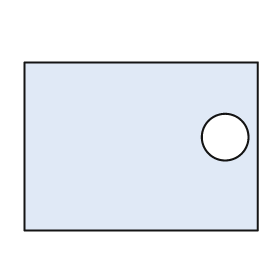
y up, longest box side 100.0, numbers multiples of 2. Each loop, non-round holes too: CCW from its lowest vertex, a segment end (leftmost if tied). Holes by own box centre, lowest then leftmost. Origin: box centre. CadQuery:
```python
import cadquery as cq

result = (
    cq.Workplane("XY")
    .moveTo(-50.0, -36.0)
    .lineTo(50.0, -36.0)
    .lineTo(50.0, 36.0)
    .lineTo(-50.0, 36.0)
    .close()
    .moveTo(36.0, 4.0)
    .circle(10.0)
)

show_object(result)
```